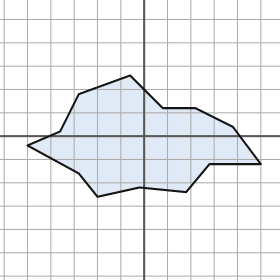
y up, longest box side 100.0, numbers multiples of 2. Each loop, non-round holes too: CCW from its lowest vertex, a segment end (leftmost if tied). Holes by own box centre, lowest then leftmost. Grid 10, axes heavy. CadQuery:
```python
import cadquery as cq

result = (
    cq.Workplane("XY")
    .moveTo(-20.0, -26.0)
    .lineTo(-2.0, -22.0)
    .lineTo(18.0, -24.0)
    .lineTo(28.0, -12.0)
    .lineTo(50.0, -12.0)
    .lineTo(38.0, 4.0)
    .lineTo(22.0, 12.0)
    .lineTo(8.0, 12.0)
    .lineTo(-6.0, 26.0)
    .lineTo(-28.0, 18.0)
    .lineTo(-36.0, 2.0)
    .lineTo(-50.0, -4.0)
    .lineTo(-28.0, -16.0)
    .close()
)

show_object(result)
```